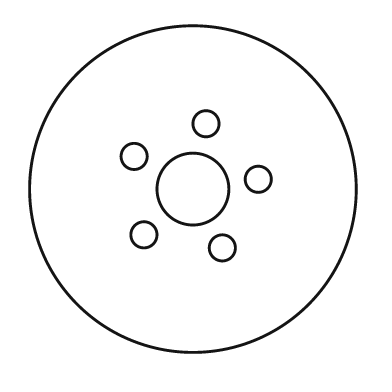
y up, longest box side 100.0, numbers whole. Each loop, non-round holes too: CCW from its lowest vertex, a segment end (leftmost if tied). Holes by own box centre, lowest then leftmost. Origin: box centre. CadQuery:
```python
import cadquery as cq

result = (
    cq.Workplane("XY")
    .moveTo(0.0, 0.0)
    .circle(50.0)
    .moveTo(9.0, -18.0)
    .circle(4.0)
    .moveTo(-15.0, -14.0)
    .circle(4.0)
    .moveTo(0.0, 0.0)
    .circle(11.0)
    .moveTo(20.0, 3.0)
    .circle(4.0)
    .moveTo(-18.0, 10.0)
    .circle(4.0)
    .moveTo(4.0, 20.0)
    .circle(4.0)
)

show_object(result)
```